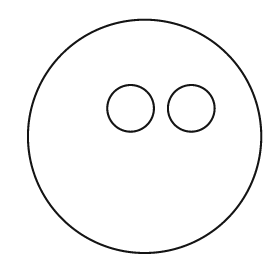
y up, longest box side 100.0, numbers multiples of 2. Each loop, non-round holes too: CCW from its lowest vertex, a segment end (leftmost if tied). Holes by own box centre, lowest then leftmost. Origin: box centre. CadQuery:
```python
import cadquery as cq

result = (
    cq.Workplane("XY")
    .moveTo(0.0, 0.0)
    .circle(50.0)
    .moveTo(-6.0, 12.0)
    .circle(10.0)
    .moveTo(20.0, 12.0)
    .circle(10.0)
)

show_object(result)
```